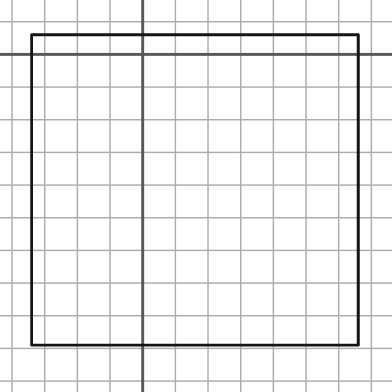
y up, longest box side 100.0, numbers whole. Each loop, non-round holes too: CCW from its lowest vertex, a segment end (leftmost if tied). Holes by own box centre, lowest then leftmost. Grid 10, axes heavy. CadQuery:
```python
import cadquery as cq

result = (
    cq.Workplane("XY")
    .moveTo(-34.0, -89.0)
    .lineTo(66.0, -89.0)
    .lineTo(66.0, 6.0)
    .lineTo(-34.0, 6.0)
    .close()
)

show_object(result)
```